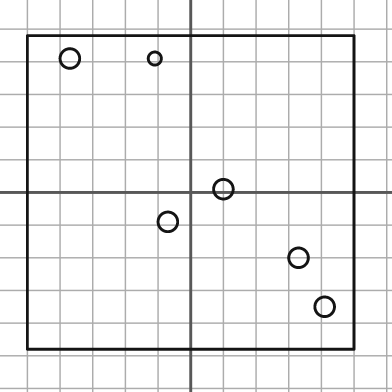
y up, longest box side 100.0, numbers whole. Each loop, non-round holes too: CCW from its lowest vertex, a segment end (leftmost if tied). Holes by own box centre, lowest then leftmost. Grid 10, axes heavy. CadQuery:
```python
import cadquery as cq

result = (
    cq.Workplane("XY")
    .moveTo(-50.0, -48.0)
    .lineTo(50.0, -48.0)
    .lineTo(50.0, 48.0)
    .lineTo(-50.0, 48.0)
    .close()
    .moveTo(41.0, -35.0)
    .circle(3.0)
    .moveTo(33.0, -20.0)
    .circle(3.0)
    .moveTo(-7.0, -9.0)
    .circle(3.0)
    .moveTo(10.0, 1.0)
    .circle(3.0)
    .moveTo(-37.0, 41.0)
    .circle(3.0)
    .moveTo(-11.0, 41.0)
    .circle(2.0)
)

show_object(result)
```